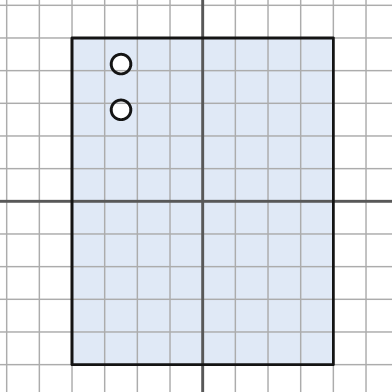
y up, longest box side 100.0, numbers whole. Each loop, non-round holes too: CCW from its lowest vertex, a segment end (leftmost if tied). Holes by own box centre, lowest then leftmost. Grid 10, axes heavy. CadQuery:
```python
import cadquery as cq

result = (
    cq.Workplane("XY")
    .moveTo(-40.0, -50.0)
    .lineTo(40.0, -50.0)
    .lineTo(40.0, 50.0)
    .lineTo(-40.0, 50.0)
    .close()
    .moveTo(-25.0, 28.0)
    .circle(3.0)
    .moveTo(-25.0, 42.0)
    .circle(3.0)
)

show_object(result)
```